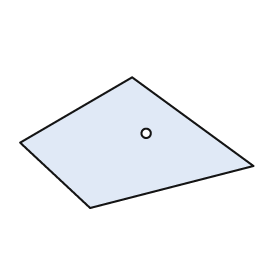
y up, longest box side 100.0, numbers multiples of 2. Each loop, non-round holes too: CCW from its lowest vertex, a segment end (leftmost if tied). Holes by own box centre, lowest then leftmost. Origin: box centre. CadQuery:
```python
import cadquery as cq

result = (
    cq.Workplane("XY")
    .moveTo(-20.0, -28.0)
    .lineTo(50.0, -10.0)
    .lineTo(-2.0, 28.0)
    .lineTo(-50.0, 0.0)
    .close()
    .moveTo(4.0, 4.0)
    .circle(2.0)
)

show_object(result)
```